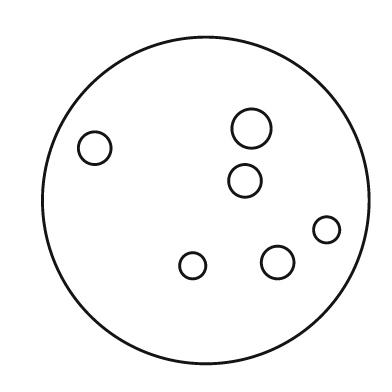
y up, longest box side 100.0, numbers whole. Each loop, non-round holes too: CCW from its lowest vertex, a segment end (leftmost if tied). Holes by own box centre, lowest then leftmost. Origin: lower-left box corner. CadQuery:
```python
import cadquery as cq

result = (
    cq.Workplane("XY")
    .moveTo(50.0, 50.0)
    .circle(50.0)
    .moveTo(46.0, 30.0)
    .circle(4.0)
    .moveTo(72.0, 31.0)
    .circle(5.0)
    .moveTo(87.0, 41.0)
    .circle(4.0)
    .moveTo(62.0, 56.0)
    .circle(5.0)
    .moveTo(16.0, 66.0)
    .circle(5.0)
    .moveTo(64.0, 72.0)
    .circle(6.0)
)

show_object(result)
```